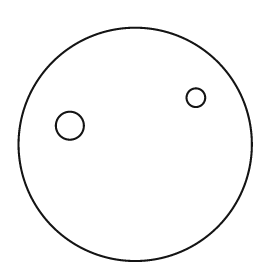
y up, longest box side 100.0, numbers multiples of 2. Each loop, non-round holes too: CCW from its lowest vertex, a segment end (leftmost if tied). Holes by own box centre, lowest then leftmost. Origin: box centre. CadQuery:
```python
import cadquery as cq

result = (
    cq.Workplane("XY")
    .moveTo(0.0, 0.0)
    .circle(50.0)
    .moveTo(-28.0, 8.0)
    .circle(6.0)
    .moveTo(26.0, 20.0)
    .circle(4.0)
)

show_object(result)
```